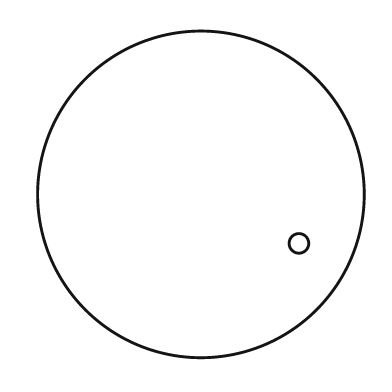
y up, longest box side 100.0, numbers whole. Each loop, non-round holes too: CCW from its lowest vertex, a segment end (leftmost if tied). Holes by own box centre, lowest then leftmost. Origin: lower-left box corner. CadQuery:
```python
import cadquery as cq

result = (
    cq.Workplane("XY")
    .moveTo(50.0, 50.0)
    .circle(50.0)
    .moveTo(80.0, 35.0)
    .circle(3.0)
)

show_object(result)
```